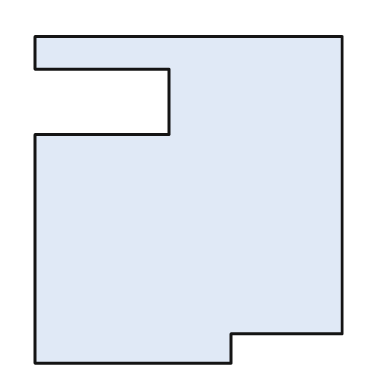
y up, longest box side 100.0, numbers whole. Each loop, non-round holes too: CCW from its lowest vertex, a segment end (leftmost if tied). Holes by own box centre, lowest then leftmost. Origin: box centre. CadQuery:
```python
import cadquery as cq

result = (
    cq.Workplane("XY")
    .moveTo(-47.0, -50.0)
    .lineTo(13.0, -50.0)
    .lineTo(13.0, -41.0)
    .lineTo(47.0, -41.0)
    .lineTo(47.0, 50.0)
    .lineTo(-47.0, 50.0)
    .lineTo(-47.0, 40.0)
    .lineTo(-6.0, 40.0)
    .lineTo(-6.0, 20.0)
    .lineTo(-47.0, 20.0)
    .close()
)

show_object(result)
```